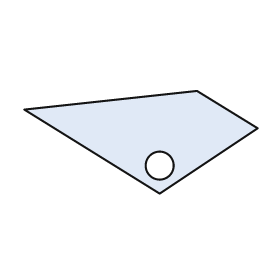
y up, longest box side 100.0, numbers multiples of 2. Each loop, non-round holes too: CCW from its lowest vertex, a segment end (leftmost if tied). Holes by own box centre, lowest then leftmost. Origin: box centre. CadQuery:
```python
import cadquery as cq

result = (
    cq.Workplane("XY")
    .moveTo(8.0, -22.0)
    .lineTo(50.0, 6.0)
    .lineTo(24.0, 22.0)
    .lineTo(-50.0, 14.0)
    .close()
    .moveTo(8.0, -10.0)
    .circle(6.0)
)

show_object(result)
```